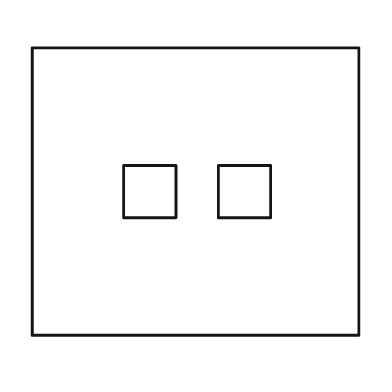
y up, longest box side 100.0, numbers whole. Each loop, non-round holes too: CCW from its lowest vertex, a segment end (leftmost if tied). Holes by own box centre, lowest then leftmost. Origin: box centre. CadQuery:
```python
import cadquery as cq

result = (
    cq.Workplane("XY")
    .moveTo(-50.0, -44.0)
    .lineTo(50.0, -44.0)
    .lineTo(50.0, 44.0)
    .lineTo(-50.0, 44.0)
    .close()
    .moveTo(-22.0, -8.0)
    .lineTo(-6.0, -8.0)
    .lineTo(-6.0, 8.0)
    .lineTo(-22.0, 8.0)
    .close()
    .moveTo(7.0, -8.0)
    .lineTo(23.0, -8.0)
    .lineTo(23.0, 8.0)
    .lineTo(7.0, 8.0)
    .close()
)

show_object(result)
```